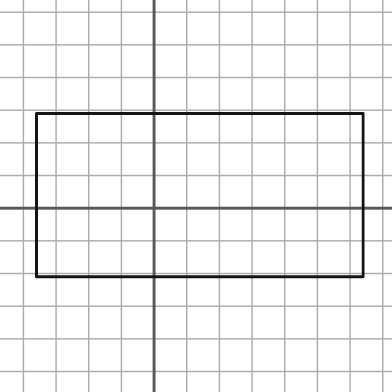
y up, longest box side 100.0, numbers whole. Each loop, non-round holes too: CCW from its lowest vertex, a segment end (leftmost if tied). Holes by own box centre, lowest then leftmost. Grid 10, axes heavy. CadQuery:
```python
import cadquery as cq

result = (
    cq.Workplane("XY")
    .moveTo(-36.0, -21.0)
    .lineTo(64.0, -21.0)
    .lineTo(64.0, 29.0)
    .lineTo(-36.0, 29.0)
    .close()
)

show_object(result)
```